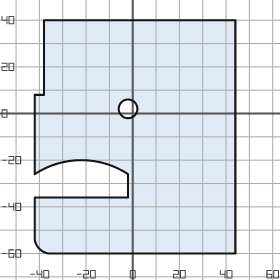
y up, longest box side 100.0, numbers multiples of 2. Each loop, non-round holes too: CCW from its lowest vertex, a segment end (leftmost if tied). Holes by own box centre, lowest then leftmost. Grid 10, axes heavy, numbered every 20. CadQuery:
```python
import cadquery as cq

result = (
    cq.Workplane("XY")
    .moveTo(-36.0, -60.0)
    .lineTo(44.0, -60.0)
    .lineTo(44.0, 40.0)
    .lineTo(-38.0, 40.0)
    .lineTo(-38.0, 8.0)
    .lineTo(-42.0, 8.0)
    .lineTo(-42.0, -26.0)
    .threePointArc((-22.0, -20.0), (-2.0, -26.0))
    .lineTo(-2.0, -36.0)
    .lineTo(-42.0, -36.0)
    .lineTo(-42.0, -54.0)
    .threePointArc((-40.0, -58.0), (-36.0, -60.0))
    .close()
    .moveTo(-2.0, 2.0)
    .circle(4.0)
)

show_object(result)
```